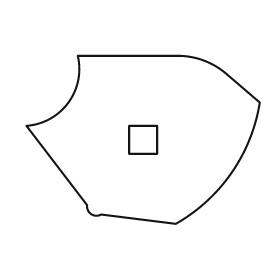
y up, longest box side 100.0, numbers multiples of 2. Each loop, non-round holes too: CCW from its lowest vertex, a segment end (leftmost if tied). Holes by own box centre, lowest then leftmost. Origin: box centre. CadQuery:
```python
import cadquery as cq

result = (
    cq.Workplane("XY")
    .moveTo(14.0, -36.0)
    .threePointArc((38.0, -14.0), (50.0, 16.0))
    .lineTo(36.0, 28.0)
    .threePointArc((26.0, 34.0), (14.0, 36.0))
    .lineTo(-28.0, 36.0)
    .threePointArc((-32.0, 16.0), (-50.0, 6.0))
    .lineTo(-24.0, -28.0)
    .threePointArc((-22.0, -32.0), (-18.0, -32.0))
    .close()
    .moveTo(-6.0, -6.0)
    .lineTo(6.0, -6.0)
    .lineTo(6.0, 6.0)
    .lineTo(-6.0, 6.0)
    .close()
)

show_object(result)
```